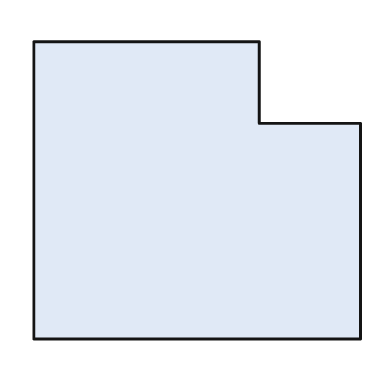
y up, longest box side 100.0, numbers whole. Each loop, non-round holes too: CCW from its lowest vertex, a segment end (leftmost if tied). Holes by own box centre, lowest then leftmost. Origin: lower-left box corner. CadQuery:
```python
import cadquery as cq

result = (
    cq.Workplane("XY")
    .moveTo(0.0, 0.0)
    .lineTo(100.0, 0.0)
    .lineTo(100.0, 66.0)
    .lineTo(69.0, 66.0)
    .lineTo(69.0, 91.0)
    .lineTo(0.0, 91.0)
    .close()
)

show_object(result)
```